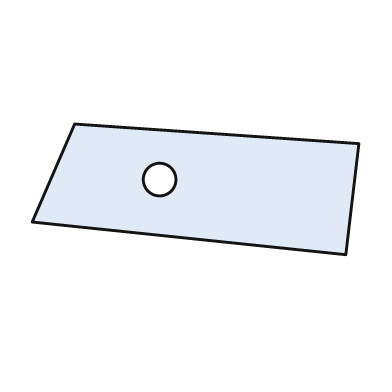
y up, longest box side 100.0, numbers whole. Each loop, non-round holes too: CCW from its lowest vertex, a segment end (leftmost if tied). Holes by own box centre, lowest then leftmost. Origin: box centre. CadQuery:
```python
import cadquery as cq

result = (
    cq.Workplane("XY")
    .moveTo(46.0, -20.0)
    .lineTo(50.0, 14.0)
    .lineTo(-37.0, 20.0)
    .lineTo(-50.0, -10.0)
    .close()
    .moveTo(-11.0, 3.0)
    .circle(5.0)
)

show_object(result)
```